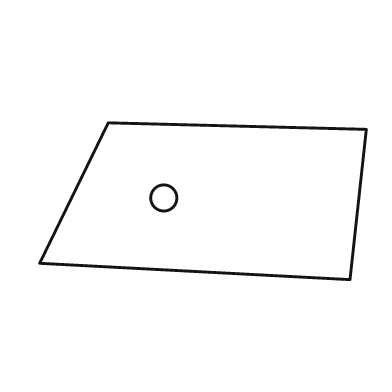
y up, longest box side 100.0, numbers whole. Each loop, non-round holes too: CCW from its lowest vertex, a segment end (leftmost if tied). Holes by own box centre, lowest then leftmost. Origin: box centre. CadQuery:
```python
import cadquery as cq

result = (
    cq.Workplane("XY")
    .moveTo(45.0, -24.0)
    .lineTo(50.0, 22.0)
    .lineTo(-29.0, 24.0)
    .lineTo(-50.0, -19.0)
    .close()
    .moveTo(-12.0, 1.0)
    .circle(4.0)
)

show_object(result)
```